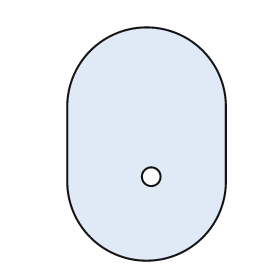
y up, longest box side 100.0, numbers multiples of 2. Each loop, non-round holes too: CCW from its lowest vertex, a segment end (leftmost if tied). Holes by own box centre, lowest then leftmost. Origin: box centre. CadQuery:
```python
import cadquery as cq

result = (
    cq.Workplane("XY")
    .moveTo(-34.0, -16.0)
    .threePointArc((0.0, -50.0), (34.0, -16.0))
    .lineTo(34.0, 16.0)
    .threePointArc((0.0, 50.0), (-34.0, 16.0))
    .close()
    .moveTo(2.0, -14.0)
    .circle(4.0)
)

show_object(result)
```